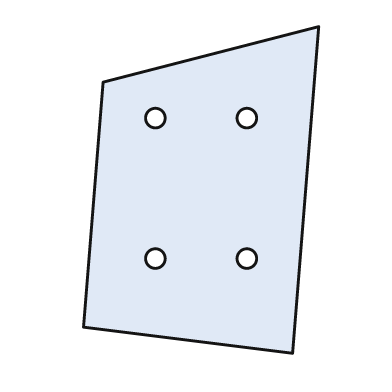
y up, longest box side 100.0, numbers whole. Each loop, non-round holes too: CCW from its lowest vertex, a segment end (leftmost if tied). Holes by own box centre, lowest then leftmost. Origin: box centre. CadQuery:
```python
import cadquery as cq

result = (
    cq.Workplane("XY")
    .moveTo(28.0, -50.0)
    .lineTo(36.0, 50.0)
    .lineTo(-30.0, 33.0)
    .lineTo(-36.0, -42.0)
    .close()
    .moveTo(-14.0, -21.0)
    .circle(3.0)
    .moveTo(14.0, -21.0)
    .circle(3.0)
    .moveTo(-14.0, 22.0)
    .circle(3.0)
    .moveTo(14.0, 22.0)
    .circle(3.0)
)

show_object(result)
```